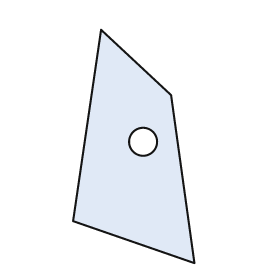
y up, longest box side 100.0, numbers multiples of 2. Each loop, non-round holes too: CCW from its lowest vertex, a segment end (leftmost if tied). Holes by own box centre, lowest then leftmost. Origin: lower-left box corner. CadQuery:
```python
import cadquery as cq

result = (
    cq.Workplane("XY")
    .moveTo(52.0, 0.0)
    .lineTo(42.0, 72.0)
    .lineTo(12.0, 100.0)
    .lineTo(0.0, 18.0)
    .close()
    .moveTo(30.0, 52.0)
    .circle(6.0)
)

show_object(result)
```